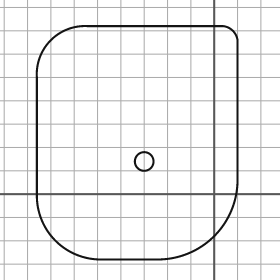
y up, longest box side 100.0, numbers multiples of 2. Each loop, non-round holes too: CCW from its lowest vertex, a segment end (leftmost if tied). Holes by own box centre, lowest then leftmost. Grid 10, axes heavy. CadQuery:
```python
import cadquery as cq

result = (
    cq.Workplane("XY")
    .moveTo(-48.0, -28.0)
    .lineTo(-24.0, -28.0)
    .threePointArc((0.0, -18.0), (10.0, 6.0))
    .lineTo(10.0, 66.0)
    .threePointArc((8.0, 70.0), (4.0, 72.0))
    .lineTo(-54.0, 72.0)
    .threePointArc((-70.0, 66.0), (-76.0, 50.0))
    .lineTo(-76.0, 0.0)
    .threePointArc((-68.0, -20.0), (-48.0, -28.0))
    .close()
    .moveTo(-30.0, 14.0)
    .circle(4.0)
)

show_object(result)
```